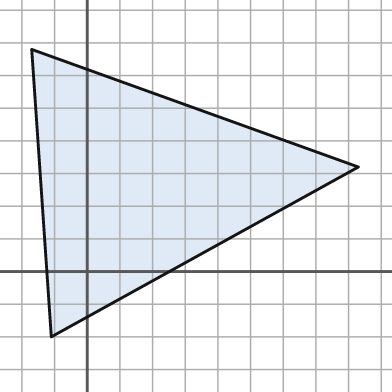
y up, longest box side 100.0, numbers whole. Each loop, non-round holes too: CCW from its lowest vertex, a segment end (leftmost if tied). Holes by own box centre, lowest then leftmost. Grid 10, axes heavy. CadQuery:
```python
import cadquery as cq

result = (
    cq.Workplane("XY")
    .moveTo(-11.0, -20.0)
    .lineTo(83.0, 32.0)
    .lineTo(-17.0, 68.0)
    .close()
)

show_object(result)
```